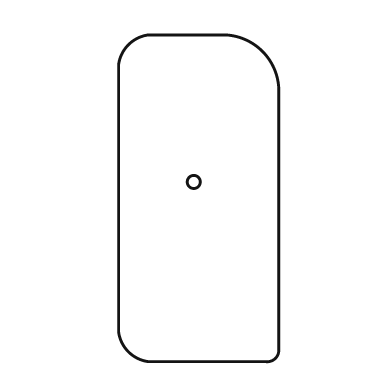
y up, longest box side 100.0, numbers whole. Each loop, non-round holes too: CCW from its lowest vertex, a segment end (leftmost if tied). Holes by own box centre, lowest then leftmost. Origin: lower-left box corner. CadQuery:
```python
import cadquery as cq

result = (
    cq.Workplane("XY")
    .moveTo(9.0, 0.0)
    .lineTo(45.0, 0.0)
    .threePointArc((48.0, 1.0), (49.0, 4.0))
    .lineTo(49.0, 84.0)
    .threePointArc((44.0, 95.0), (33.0, 100.0))
    .lineTo(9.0, 100.0)
    .threePointArc((3.0, 97.0), (0.0, 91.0))
    .lineTo(0.0, 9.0)
    .threePointArc((3.0, 3.0), (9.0, 0.0))
    .close()
    .moveTo(23.0, 55.0)
    .circle(2.0)
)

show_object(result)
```